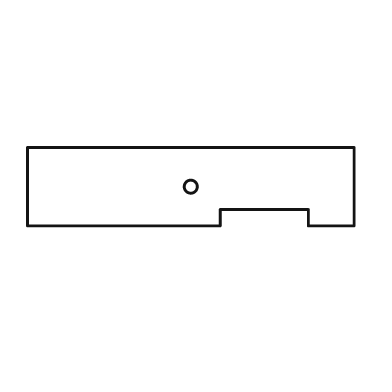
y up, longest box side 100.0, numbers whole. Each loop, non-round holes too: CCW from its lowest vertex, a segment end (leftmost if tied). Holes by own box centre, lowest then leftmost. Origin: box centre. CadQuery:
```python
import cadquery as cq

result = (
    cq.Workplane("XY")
    .moveTo(-50.0, -12.0)
    .lineTo(9.0, -12.0)
    .lineTo(9.0, -7.0)
    .lineTo(36.0, -7.0)
    .lineTo(36.0, -12.0)
    .lineTo(50.0, -12.0)
    .lineTo(50.0, 12.0)
    .lineTo(-50.0, 12.0)
    .close()
    .moveTo(0.0, 0.0)
    .circle(2.0)
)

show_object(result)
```